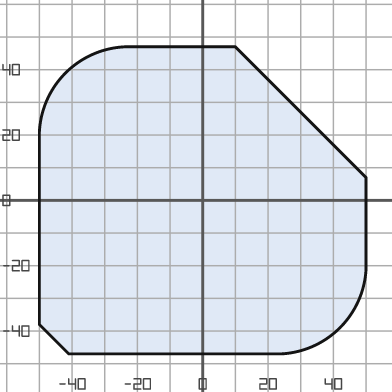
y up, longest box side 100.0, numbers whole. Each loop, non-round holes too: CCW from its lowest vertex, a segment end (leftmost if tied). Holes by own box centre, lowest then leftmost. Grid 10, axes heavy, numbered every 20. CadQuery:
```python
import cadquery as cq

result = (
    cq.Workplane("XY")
    .moveTo(-41.0, -47.0)
    .lineTo(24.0, -47.0)
    .threePointArc((42.0, -39.0), (50.0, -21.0))
    .lineTo(50.0, 7.0)
    .lineTo(10.0, 47.0)
    .lineTo(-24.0, 47.0)
    .threePointArc((-42.0, 39.0), (-50.0, 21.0))
    .lineTo(-50.0, -38.0)
    .close()
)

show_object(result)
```